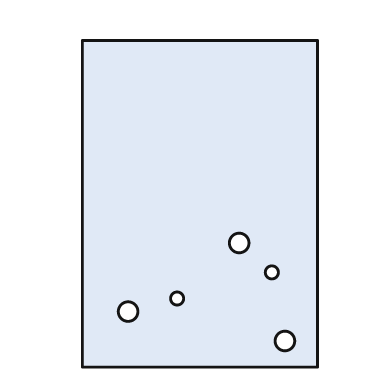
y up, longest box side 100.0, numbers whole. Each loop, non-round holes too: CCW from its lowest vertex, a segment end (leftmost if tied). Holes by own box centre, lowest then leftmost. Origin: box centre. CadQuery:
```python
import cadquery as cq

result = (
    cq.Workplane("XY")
    .moveTo(-36.0, -50.0)
    .lineTo(36.0, -50.0)
    .lineTo(36.0, 50.0)
    .lineTo(-36.0, 50.0)
    .close()
    .moveTo(26.0, -42.0)
    .circle(3.0)
    .moveTo(-22.0, -33.0)
    .circle(3.0)
    .moveTo(-7.0, -29.0)
    .circle(2.0)
    .moveTo(22.0, -21.0)
    .circle(2.0)
    .moveTo(12.0, -12.0)
    .circle(3.0)
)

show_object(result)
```